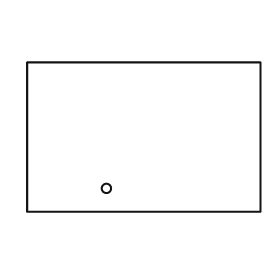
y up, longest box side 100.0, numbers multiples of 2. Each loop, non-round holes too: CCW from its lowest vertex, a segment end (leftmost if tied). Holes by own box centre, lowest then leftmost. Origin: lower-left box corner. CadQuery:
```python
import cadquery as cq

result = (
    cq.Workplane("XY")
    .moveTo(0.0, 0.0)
    .lineTo(100.0, 0.0)
    .lineTo(100.0, 64.0)
    .lineTo(0.0, 64.0)
    .close()
    .moveTo(34.0, 10.0)
    .circle(2.0)
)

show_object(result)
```